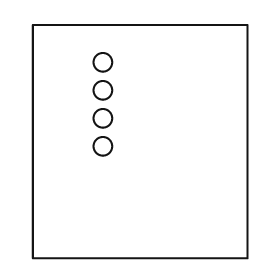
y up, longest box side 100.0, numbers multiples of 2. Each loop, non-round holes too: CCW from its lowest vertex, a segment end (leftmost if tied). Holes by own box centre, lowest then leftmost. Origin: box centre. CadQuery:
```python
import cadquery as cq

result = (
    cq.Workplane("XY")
    .moveTo(-46.0, -50.0)
    .lineTo(46.0, -50.0)
    .lineTo(46.0, 50.0)
    .lineTo(-46.0, 50.0)
    .close()
    .moveTo(-16.0, -2.0)
    .circle(4.0)
    .moveTo(-16.0, 10.0)
    .circle(4.0)
    .moveTo(-16.0, 22.0)
    .circle(4.0)
    .moveTo(-16.0, 34.0)
    .circle(4.0)
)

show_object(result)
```